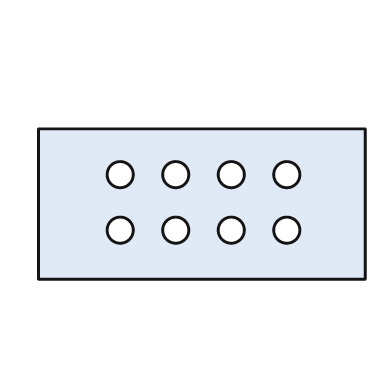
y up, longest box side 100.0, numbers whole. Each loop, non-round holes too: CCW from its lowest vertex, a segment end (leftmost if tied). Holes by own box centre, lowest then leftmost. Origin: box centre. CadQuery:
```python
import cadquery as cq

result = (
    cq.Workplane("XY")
    .moveTo(-50.0, -23.0)
    .lineTo(50.0, -23.0)
    .lineTo(50.0, 23.0)
    .lineTo(-50.0, 23.0)
    .close()
    .moveTo(-25.0, -8.0)
    .circle(4.0)
    .moveTo(-8.0, -8.0)
    .circle(4.0)
    .moveTo(9.0, -8.0)
    .circle(4.0)
    .moveTo(26.0, -8.0)
    .circle(4.0)
    .moveTo(-25.0, 9.0)
    .circle(4.0)
    .moveTo(-8.0, 9.0)
    .circle(4.0)
    .moveTo(9.0, 9.0)
    .circle(4.0)
    .moveTo(26.0, 9.0)
    .circle(4.0)
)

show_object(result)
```